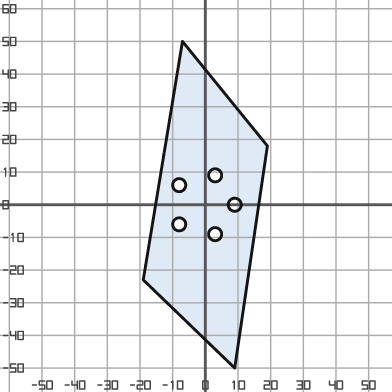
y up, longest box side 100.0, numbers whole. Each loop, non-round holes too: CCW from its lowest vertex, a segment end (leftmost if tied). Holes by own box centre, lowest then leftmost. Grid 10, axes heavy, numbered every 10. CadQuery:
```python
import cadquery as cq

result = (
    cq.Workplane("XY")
    .moveTo(9.0, -50.0)
    .lineTo(19.0, 18.0)
    .lineTo(-7.0, 50.0)
    .lineTo(-19.0, -23.0)
    .close()
    .moveTo(3.0, -9.0)
    .circle(2.0)
    .moveTo(-8.0, -6.0)
    .circle(2.0)
    .moveTo(9.0, 0.0)
    .circle(2.0)
    .moveTo(-8.0, 6.0)
    .circle(2.0)
    .moveTo(3.0, 9.0)
    .circle(2.0)
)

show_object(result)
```